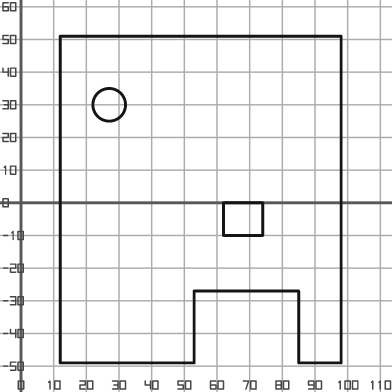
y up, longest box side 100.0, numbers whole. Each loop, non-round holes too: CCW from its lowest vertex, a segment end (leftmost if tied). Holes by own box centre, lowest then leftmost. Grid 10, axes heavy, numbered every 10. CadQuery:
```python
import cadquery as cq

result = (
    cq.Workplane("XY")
    .moveTo(12.0, -49.0)
    .lineTo(53.0, -49.0)
    .lineTo(53.0, -27.0)
    .lineTo(85.0, -27.0)
    .lineTo(85.0, -49.0)
    .lineTo(98.0, -49.0)
    .lineTo(98.0, 51.0)
    .lineTo(12.0, 51.0)
    .close()
    .moveTo(62.0, -10.0)
    .lineTo(74.0, -10.0)
    .lineTo(74.0, 0.0)
    .lineTo(62.0, 0.0)
    .close()
    .moveTo(27.0, 30.0)
    .circle(5.0)
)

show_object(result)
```